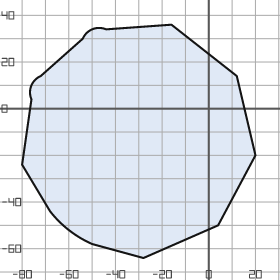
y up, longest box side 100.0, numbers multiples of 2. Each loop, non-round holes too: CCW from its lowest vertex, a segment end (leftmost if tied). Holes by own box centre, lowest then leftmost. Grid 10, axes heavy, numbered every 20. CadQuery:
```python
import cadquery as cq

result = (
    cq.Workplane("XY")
    .moveTo(-28.0, -64.0)
    .lineTo(4.0, -50.0)
    .lineTo(20.0, -20.0)
    .lineTo(12.0, 14.0)
    .lineTo(-16.0, 36.0)
    .lineTo(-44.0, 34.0)
    .threePointArc((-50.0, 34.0), (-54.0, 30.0))
    .lineTo(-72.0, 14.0)
    .threePointArc((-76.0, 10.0), (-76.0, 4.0))
    .lineTo(-80.0, -24.0)
    .lineTo(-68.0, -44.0)
    .threePointArc((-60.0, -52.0), (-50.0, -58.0))
    .close()
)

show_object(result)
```